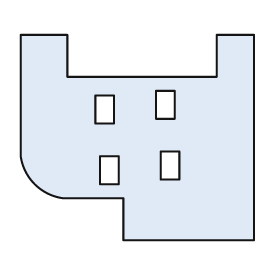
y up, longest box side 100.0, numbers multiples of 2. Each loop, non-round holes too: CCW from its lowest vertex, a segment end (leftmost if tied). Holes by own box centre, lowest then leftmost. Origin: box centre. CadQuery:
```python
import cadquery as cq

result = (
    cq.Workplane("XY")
    .moveTo(-6.0, -44.0)
    .lineTo(50.0, -44.0)
    .lineTo(50.0, 44.0)
    .lineTo(34.0, 44.0)
    .lineTo(34.0, 26.0)
    .lineTo(-30.0, 26.0)
    .lineTo(-30.0, 44.0)
    .lineTo(-50.0, 44.0)
    .lineTo(-50.0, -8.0)
    .threePointArc((-44.0, -20.0), (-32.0, -26.0))
    .lineTo(-6.0, -26.0)
    .close()
    .moveTo(-16.0, -20.0)
    .lineTo(-8.0, -20.0)
    .lineTo(-8.0, -8.0)
    .lineTo(-16.0, -8.0)
    .close()
    .moveTo(10.0, -18.0)
    .lineTo(18.0, -18.0)
    .lineTo(18.0, -6.0)
    .lineTo(10.0, -6.0)
    .close()
    .moveTo(-18.0, 6.0)
    .lineTo(-10.0, 6.0)
    .lineTo(-10.0, 18.0)
    .lineTo(-18.0, 18.0)
    .close()
    .moveTo(8.0, 8.0)
    .lineTo(16.0, 8.0)
    .lineTo(16.0, 20.0)
    .lineTo(8.0, 20.0)
    .close()
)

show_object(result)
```